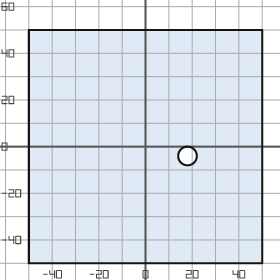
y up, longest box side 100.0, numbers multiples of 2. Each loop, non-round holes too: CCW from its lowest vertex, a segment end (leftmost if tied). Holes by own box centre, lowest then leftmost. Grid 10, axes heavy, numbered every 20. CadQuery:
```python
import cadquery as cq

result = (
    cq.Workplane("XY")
    .moveTo(-50.0, -50.0)
    .lineTo(50.0, -50.0)
    .lineTo(50.0, 50.0)
    .lineTo(-50.0, 50.0)
    .close()
    .moveTo(18.0, -4.0)
    .circle(4.0)
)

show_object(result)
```